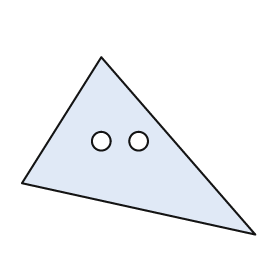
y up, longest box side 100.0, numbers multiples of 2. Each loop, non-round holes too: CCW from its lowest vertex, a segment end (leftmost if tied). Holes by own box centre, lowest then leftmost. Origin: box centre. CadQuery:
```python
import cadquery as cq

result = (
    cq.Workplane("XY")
    .moveTo(50.0, -38.0)
    .lineTo(-16.0, 38.0)
    .lineTo(-50.0, -16.0)
    .close()
    .moveTo(-16.0, 2.0)
    .circle(4.0)
    .moveTo(0.0, 2.0)
    .circle(4.0)
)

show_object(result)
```